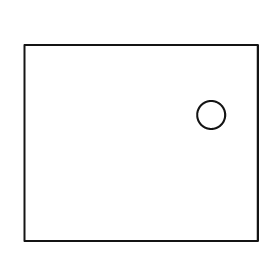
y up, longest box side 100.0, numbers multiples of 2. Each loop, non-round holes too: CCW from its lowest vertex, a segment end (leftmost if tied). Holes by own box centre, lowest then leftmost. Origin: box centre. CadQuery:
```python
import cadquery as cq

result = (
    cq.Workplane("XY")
    .moveTo(-50.0, -42.0)
    .lineTo(50.0, -42.0)
    .lineTo(50.0, 42.0)
    .lineTo(-50.0, 42.0)
    .close()
    .moveTo(30.0, 12.0)
    .circle(6.0)
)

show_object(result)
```